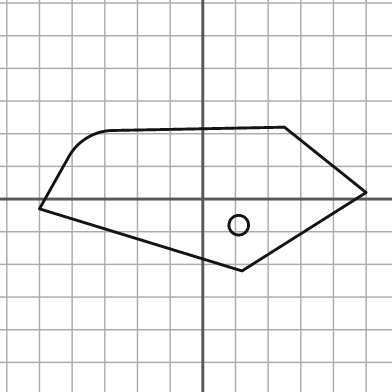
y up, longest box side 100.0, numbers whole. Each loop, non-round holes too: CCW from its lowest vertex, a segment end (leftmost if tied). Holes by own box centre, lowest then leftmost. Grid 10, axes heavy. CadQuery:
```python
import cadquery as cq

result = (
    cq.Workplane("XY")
    .moveTo(12.0, -22.0)
    .lineTo(50.0, 2.0)
    .lineTo(25.0, 22.0)
    .lineTo(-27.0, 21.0)
    .threePointArc((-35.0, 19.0), (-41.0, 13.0))
    .lineTo(-50.0, -3.0)
    .close()
    .moveTo(11.0, -8.0)
    .circle(3.0)
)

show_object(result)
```